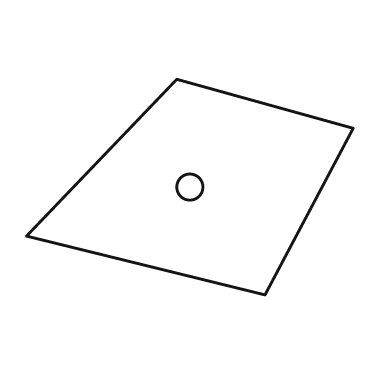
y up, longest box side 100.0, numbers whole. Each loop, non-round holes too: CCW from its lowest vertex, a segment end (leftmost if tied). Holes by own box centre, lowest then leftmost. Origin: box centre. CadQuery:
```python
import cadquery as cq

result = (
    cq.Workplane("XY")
    .moveTo(23.0, -33.0)
    .lineTo(50.0, 18.0)
    .lineTo(-4.0, 33.0)
    .lineTo(-50.0, -15.0)
    .close()
    .moveTo(0.0, 0.0)
    .circle(4.0)
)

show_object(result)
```